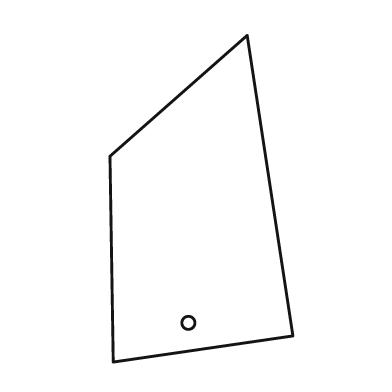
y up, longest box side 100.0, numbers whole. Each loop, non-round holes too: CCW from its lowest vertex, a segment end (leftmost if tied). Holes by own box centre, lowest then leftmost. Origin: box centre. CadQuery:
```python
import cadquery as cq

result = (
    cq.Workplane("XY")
    .moveTo(-27.0, -50.0)
    .lineTo(28.0, -42.0)
    .lineTo(14.0, 50.0)
    .lineTo(-28.0, 13.0)
    .close()
    .moveTo(-4.0, -38.0)
    .circle(2.0)
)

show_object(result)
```